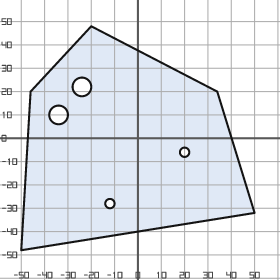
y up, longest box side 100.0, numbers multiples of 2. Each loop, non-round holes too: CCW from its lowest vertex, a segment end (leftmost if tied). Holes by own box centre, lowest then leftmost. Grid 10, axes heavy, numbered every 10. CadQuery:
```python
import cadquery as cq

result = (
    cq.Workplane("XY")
    .moveTo(-50.0, -48.0)
    .lineTo(50.0, -32.0)
    .lineTo(34.0, 20.0)
    .lineTo(-20.0, 48.0)
    .lineTo(-46.0, 20.0)
    .close()
    .moveTo(-12.0, -28.0)
    .circle(2.0)
    .moveTo(20.0, -6.0)
    .circle(2.0)
    .moveTo(-34.0, 10.0)
    .circle(4.0)
    .moveTo(-24.0, 22.0)
    .circle(4.0)
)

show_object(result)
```